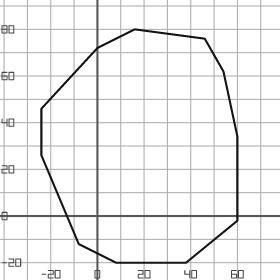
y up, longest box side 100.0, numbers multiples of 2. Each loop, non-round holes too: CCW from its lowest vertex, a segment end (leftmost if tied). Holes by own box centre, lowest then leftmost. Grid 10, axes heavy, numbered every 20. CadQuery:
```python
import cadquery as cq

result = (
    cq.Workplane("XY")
    .moveTo(8.0, -20.0)
    .lineTo(38.0, -20.0)
    .lineTo(60.0, -2.0)
    .lineTo(60.0, 34.0)
    .lineTo(54.0, 62.0)
    .lineTo(46.0, 76.0)
    .lineTo(16.0, 80.0)
    .lineTo(0.0, 72.0)
    .lineTo(-24.0, 46.0)
    .lineTo(-24.0, 26.0)
    .lineTo(-8.0, -12.0)
    .close()
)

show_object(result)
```